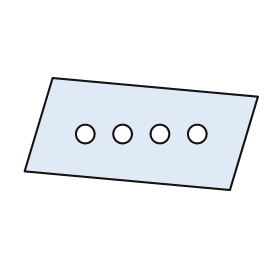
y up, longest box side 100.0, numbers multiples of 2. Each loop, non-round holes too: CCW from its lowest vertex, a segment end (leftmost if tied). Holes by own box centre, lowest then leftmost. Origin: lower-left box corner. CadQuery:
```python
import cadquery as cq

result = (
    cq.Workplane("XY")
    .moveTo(88.0, 0.0)
    .lineTo(100.0, 40.0)
    .lineTo(12.0, 48.0)
    .lineTo(0.0, 8.0)
    .close()
    .moveTo(26.0, 24.0)
    .circle(4.0)
    .moveTo(42.0, 24.0)
    .circle(4.0)
    .moveTo(58.0, 24.0)
    .circle(4.0)
    .moveTo(74.0, 24.0)
    .circle(4.0)
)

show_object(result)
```